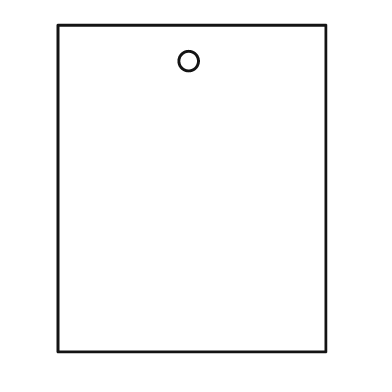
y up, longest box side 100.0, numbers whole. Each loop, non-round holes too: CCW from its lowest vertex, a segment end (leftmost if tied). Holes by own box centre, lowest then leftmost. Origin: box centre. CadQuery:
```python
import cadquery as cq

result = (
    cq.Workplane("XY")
    .moveTo(-41.0, -50.0)
    .lineTo(41.0, -50.0)
    .lineTo(41.0, 50.0)
    .lineTo(-41.0, 50.0)
    .close()
    .moveTo(-1.0, 39.0)
    .circle(3.0)
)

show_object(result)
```